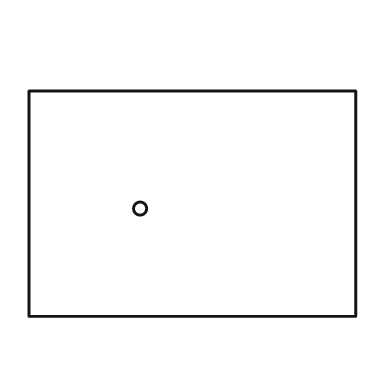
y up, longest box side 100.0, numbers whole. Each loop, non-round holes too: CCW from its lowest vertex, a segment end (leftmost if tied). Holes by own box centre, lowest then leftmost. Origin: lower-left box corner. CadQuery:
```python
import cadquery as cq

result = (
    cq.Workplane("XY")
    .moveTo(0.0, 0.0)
    .lineTo(100.0, 0.0)
    .lineTo(100.0, 69.0)
    .lineTo(0.0, 69.0)
    .close()
    .moveTo(34.0, 33.0)
    .circle(2.0)
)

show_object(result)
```